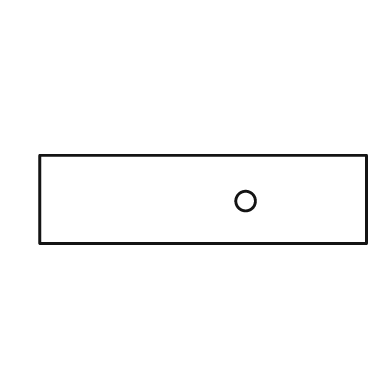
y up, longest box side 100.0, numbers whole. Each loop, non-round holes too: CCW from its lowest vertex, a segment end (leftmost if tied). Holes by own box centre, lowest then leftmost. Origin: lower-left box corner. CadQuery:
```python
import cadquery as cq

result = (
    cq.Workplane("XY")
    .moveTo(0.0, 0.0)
    .lineTo(100.0, 0.0)
    .lineTo(100.0, 27.0)
    .lineTo(0.0, 27.0)
    .close()
    .moveTo(63.0, 13.0)
    .circle(3.0)
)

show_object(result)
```